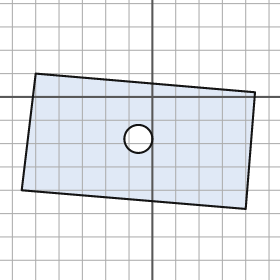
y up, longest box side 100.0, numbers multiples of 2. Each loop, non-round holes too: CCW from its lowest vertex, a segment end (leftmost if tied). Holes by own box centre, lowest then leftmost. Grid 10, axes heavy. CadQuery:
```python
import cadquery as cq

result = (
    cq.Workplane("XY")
    .moveTo(40.0, -48.0)
    .lineTo(44.0, 2.0)
    .lineTo(-50.0, 10.0)
    .lineTo(-56.0, -40.0)
    .close()
    .moveTo(-6.0, -18.0)
    .circle(6.0)
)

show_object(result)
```